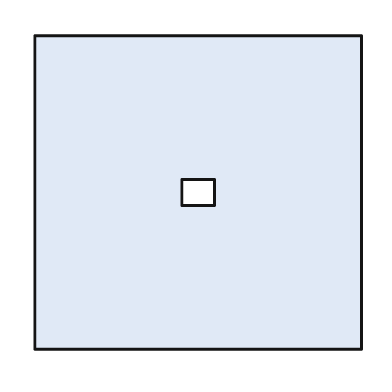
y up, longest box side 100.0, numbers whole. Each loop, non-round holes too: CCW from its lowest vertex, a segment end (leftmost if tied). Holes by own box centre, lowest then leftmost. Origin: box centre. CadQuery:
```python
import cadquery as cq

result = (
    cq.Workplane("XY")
    .moveTo(-50.0, -48.0)
    .lineTo(50.0, -48.0)
    .lineTo(50.0, 48.0)
    .lineTo(-50.0, 48.0)
    .close()
    .moveTo(-5.0, -4.0)
    .lineTo(5.0, -4.0)
    .lineTo(5.0, 4.0)
    .lineTo(-5.0, 4.0)
    .close()
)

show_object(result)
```